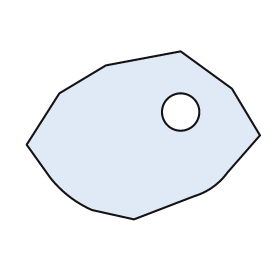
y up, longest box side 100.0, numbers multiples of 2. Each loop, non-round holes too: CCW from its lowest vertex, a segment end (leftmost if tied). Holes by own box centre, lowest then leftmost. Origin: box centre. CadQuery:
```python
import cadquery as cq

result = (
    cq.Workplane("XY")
    .moveTo(-4.0, -36.0)
    .lineTo(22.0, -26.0)
    .threePointArc((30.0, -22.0), (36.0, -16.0))
    .lineTo(50.0, 0.0)
    .lineTo(38.0, 20.0)
    .lineTo(16.0, 36.0)
    .lineTo(-16.0, 30.0)
    .lineTo(-36.0, 18.0)
    .lineTo(-50.0, -4.0)
    .lineTo(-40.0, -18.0)
    .threePointArc((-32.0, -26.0), (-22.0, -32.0))
    .close()
    .moveTo(16.0, 10.0)
    .circle(8.0)
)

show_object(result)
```